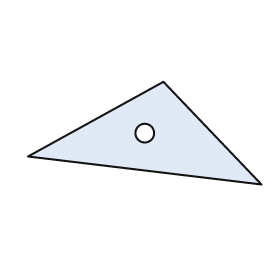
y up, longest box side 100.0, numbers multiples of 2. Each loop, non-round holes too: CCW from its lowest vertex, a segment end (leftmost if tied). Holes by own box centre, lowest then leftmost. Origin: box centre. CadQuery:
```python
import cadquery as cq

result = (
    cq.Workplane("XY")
    .moveTo(50.0, -22.0)
    .lineTo(8.0, 22.0)
    .lineTo(-50.0, -10.0)
    .close()
    .moveTo(0.0, 0.0)
    .circle(4.0)
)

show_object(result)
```